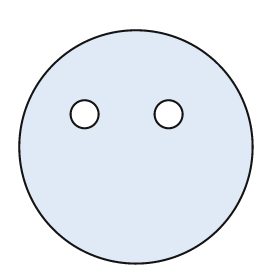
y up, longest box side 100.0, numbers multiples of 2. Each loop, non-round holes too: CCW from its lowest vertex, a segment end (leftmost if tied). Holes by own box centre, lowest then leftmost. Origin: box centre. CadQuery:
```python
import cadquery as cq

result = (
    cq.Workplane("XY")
    .moveTo(0.0, 0.0)
    .circle(50.0)
    .moveTo(-22.0, 14.0)
    .circle(6.0)
    .moveTo(14.0, 14.0)
    .circle(6.0)
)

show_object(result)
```